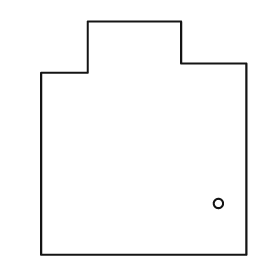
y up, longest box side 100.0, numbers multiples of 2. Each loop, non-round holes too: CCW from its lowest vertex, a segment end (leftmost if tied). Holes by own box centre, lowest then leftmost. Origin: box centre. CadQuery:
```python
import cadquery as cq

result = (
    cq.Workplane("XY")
    .moveTo(-44.0, -50.0)
    .lineTo(44.0, -50.0)
    .lineTo(44.0, 32.0)
    .lineTo(16.0, 32.0)
    .lineTo(16.0, 50.0)
    .lineTo(-24.0, 50.0)
    .lineTo(-24.0, 28.0)
    .lineTo(-44.0, 28.0)
    .close()
    .moveTo(32.0, -28.0)
    .circle(2.0)
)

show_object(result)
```